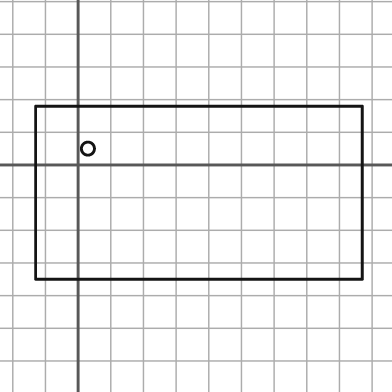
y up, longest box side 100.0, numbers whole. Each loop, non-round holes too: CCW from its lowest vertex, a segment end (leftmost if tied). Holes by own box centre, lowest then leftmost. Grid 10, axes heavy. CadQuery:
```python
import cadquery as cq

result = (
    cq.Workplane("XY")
    .moveTo(-13.0, -35.0)
    .lineTo(87.0, -35.0)
    .lineTo(87.0, 18.0)
    .lineTo(-13.0, 18.0)
    .close()
    .moveTo(3.0, 5.0)
    .circle(2.0)
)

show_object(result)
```